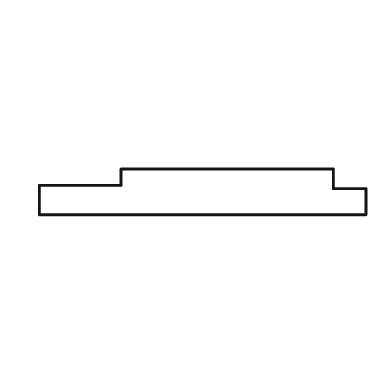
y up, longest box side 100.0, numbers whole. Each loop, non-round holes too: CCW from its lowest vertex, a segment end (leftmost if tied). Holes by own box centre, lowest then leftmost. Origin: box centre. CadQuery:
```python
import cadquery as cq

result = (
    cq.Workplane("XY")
    .moveTo(-50.0, -7.0)
    .lineTo(50.0, -7.0)
    .lineTo(50.0, 1.0)
    .lineTo(40.0, 1.0)
    .lineTo(40.0, 7.0)
    .lineTo(-25.0, 7.0)
    .lineTo(-25.0, 2.0)
    .lineTo(-50.0, 2.0)
    .close()
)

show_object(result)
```